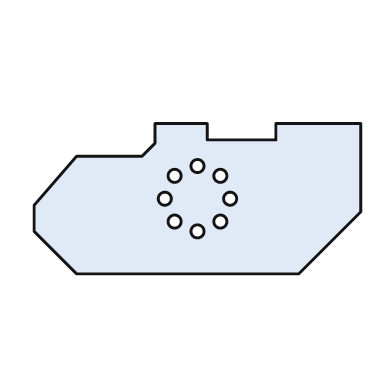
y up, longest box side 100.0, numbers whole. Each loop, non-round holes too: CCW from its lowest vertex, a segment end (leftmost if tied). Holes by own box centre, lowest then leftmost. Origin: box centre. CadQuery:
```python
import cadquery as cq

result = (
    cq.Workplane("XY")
    .moveTo(-37.0, -23.0)
    .lineTo(31.0, -23.0)
    .lineTo(50.0, -4.0)
    .lineTo(50.0, 23.0)
    .lineTo(24.0, 23.0)
    .lineTo(24.0, 18.0)
    .lineTo(3.0, 18.0)
    .lineTo(3.0, 23.0)
    .lineTo(-13.0, 23.0)
    .lineTo(-13.0, 17.0)
    .lineTo(-17.0, 13.0)
    .lineTo(-37.0, 13.0)
    .lineTo(-50.0, -2.0)
    .lineTo(-50.0, -10.0)
    .close()
    .moveTo(0.0, -10.0)
    .circle(2.0)
    .moveTo(-7.0, -7.0)
    .circle(2.0)
    .moveTo(7.0, -7.0)
    .circle(2.0)
    .moveTo(-10.0, 0.0)
    .circle(2.0)
    .moveTo(10.0, 0.0)
    .circle(2.0)
    .moveTo(-7.0, 7.0)
    .circle(2.0)
    .moveTo(7.0, 7.0)
    .circle(2.0)
    .moveTo(0.0, 10.0)
    .circle(2.0)
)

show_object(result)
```